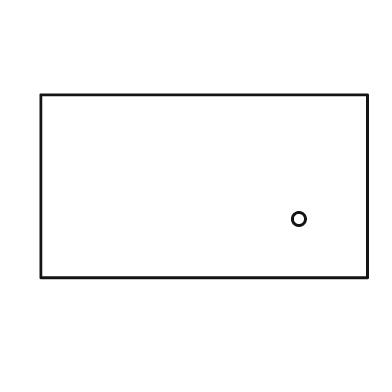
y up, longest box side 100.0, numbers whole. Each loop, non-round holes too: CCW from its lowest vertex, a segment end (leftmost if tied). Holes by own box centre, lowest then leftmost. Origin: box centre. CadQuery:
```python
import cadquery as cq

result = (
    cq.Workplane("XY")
    .moveTo(-50.0, -28.0)
    .lineTo(50.0, -28.0)
    .lineTo(50.0, 28.0)
    .lineTo(-50.0, 28.0)
    .close()
    .moveTo(29.0, -10.0)
    .circle(2.0)
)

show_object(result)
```